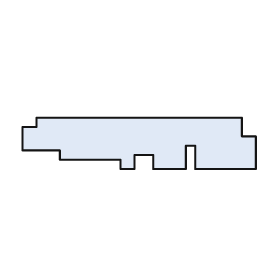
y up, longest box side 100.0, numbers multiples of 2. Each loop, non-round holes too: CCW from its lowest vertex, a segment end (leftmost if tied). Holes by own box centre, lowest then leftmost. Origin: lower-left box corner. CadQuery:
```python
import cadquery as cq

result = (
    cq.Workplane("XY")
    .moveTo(42.0, 0.0)
    .lineTo(48.0, 0.0)
    .lineTo(48.0, 6.0)
    .lineTo(56.0, 6.0)
    .lineTo(56.0, 0.0)
    .lineTo(70.0, 0.0)
    .lineTo(70.0, 10.0)
    .lineTo(74.0, 10.0)
    .lineTo(74.0, 0.0)
    .lineTo(100.0, 0.0)
    .lineTo(100.0, 14.0)
    .lineTo(94.0, 14.0)
    .lineTo(94.0, 22.0)
    .lineTo(6.0, 22.0)
    .lineTo(6.0, 18.0)
    .lineTo(0.0, 18.0)
    .lineTo(0.0, 8.0)
    .lineTo(16.0, 8.0)
    .lineTo(16.0, 4.0)
    .lineTo(42.0, 4.0)
    .close()
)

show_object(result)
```